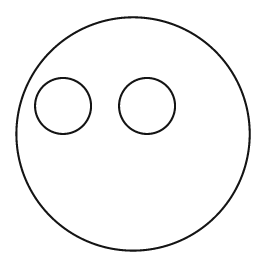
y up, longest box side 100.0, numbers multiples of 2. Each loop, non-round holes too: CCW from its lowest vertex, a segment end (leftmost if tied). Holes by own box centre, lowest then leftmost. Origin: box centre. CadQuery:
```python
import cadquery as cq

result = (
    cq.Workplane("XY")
    .moveTo(0.0, 0.0)
    .circle(50.0)
    .moveTo(-30.0, 12.0)
    .circle(12.0)
    .moveTo(6.0, 12.0)
    .circle(12.0)
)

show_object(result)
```